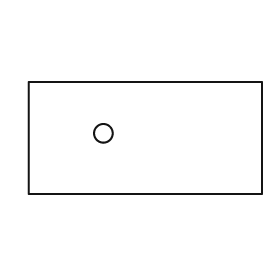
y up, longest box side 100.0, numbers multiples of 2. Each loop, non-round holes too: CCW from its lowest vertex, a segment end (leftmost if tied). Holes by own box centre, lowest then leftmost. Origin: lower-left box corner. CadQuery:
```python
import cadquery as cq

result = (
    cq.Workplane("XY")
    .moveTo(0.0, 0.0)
    .lineTo(100.0, 0.0)
    .lineTo(100.0, 48.0)
    .lineTo(0.0, 48.0)
    .close()
    .moveTo(32.0, 26.0)
    .circle(4.0)
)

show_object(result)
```